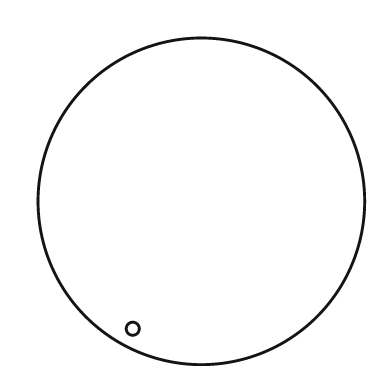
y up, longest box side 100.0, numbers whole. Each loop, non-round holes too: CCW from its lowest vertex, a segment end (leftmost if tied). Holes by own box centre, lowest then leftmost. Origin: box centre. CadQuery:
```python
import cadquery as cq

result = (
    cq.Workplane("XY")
    .moveTo(0.0, 0.0)
    .circle(50.0)
    .moveTo(-21.0, -39.0)
    .circle(2.0)
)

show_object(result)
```